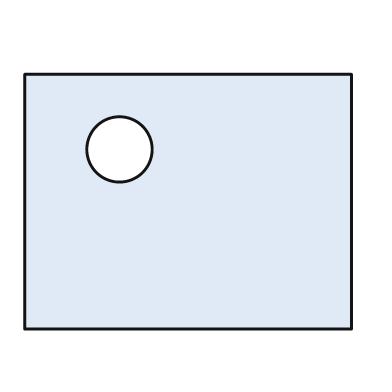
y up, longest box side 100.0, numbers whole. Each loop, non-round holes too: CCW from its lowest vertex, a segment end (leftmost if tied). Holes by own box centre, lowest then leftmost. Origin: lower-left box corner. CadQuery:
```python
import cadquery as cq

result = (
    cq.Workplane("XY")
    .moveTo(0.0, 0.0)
    .lineTo(100.0, 0.0)
    .lineTo(100.0, 78.0)
    .lineTo(0.0, 78.0)
    .close()
    .moveTo(29.0, 55.0)
    .circle(10.0)
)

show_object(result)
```